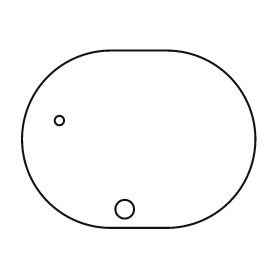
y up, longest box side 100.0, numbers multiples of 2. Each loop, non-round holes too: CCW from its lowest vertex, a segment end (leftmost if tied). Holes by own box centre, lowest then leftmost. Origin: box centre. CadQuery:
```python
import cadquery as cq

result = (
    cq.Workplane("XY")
    .moveTo(-12.0, -38.0)
    .lineTo(12.0, -38.0)
    .threePointArc((50.0, 0.0), (12.0, 38.0))
    .lineTo(-12.0, 38.0)
    .threePointArc((-50.0, 0.0), (-12.0, -38.0))
    .close()
    .moveTo(-6.0, -30.0)
    .circle(4.0)
    .moveTo(-34.0, 8.0)
    .circle(2.0)
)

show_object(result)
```